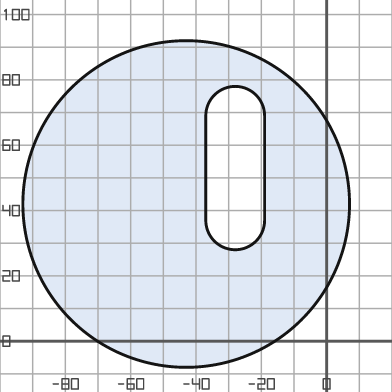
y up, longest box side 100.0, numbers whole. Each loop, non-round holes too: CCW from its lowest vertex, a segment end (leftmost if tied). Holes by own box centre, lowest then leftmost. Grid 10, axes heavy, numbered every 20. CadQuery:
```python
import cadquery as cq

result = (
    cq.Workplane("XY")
    .moveTo(-43.0, 42.0)
    .circle(50.0)
    .moveTo(-37.0, 37.0)
    .threePointArc((-28.0, 28.0), (-19.0, 37.0))
    .lineTo(-19.0, 69.0)
    .threePointArc((-28.0, 78.0), (-37.0, 69.0))
    .close()
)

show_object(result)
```